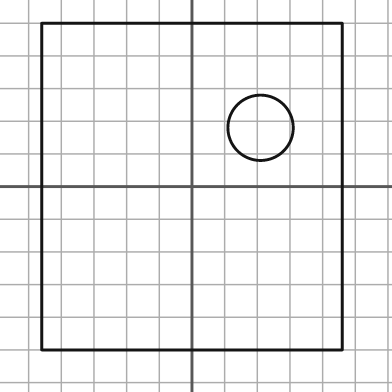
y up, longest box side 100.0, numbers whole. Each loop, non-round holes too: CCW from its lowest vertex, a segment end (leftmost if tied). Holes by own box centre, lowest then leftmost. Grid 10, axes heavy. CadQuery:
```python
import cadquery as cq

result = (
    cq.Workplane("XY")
    .moveTo(-46.0, -50.0)
    .lineTo(46.0, -50.0)
    .lineTo(46.0, 50.0)
    .lineTo(-46.0, 50.0)
    .close()
    .moveTo(21.0, 18.0)
    .circle(10.0)
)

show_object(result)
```